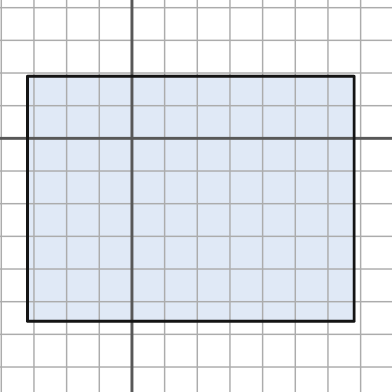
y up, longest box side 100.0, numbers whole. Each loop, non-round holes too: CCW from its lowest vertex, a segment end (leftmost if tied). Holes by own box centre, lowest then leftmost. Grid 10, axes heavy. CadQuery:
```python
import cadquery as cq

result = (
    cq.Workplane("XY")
    .moveTo(-32.0, -56.0)
    .lineTo(68.0, -56.0)
    .lineTo(68.0, 19.0)
    .lineTo(-32.0, 19.0)
    .close()
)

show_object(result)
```